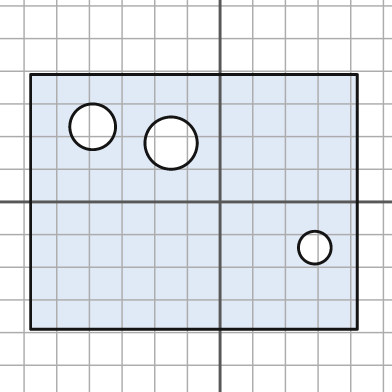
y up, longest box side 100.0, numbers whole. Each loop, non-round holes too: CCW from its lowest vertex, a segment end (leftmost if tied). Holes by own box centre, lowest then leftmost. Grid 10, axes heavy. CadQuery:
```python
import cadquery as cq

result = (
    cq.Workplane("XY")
    .moveTo(-58.0, -39.0)
    .lineTo(42.0, -39.0)
    .lineTo(42.0, 39.0)
    .lineTo(-58.0, 39.0)
    .close()
    .moveTo(29.0, -14.0)
    .circle(5.0)
    .moveTo(-15.0, 18.0)
    .circle(8.0)
    .moveTo(-39.0, 23.0)
    .circle(7.0)
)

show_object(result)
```